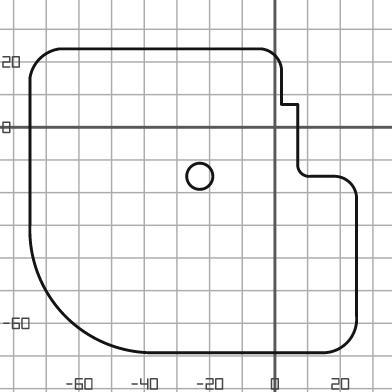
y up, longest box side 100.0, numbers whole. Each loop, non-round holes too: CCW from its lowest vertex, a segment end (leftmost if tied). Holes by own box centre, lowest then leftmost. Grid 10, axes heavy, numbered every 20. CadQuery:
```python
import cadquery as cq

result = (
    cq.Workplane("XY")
    .moveTo(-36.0, -69.0)
    .lineTo(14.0, -69.0)
    .threePointArc((22.0, -66.0), (25.0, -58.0))
    .lineTo(25.0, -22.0)
    .threePointArc((23.0, -17.0), (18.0, -15.0))
    .lineTo(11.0, -15.0)
    .threePointArc((8.0, -14.0), (7.0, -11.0))
    .lineTo(7.0, 7.0)
    .lineTo(2.0, 7.0)
    .lineTo(2.0, 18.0)
    .threePointArc((0.0, 22.0), (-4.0, 24.0))
    .lineTo(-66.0, 24.0)
    .threePointArc((-72.0, 21.0), (-75.0, 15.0))
    .lineTo(-75.0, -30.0)
    .threePointArc((-64.0, -58.0), (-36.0, -69.0))
    .close()
    .moveTo(-23.0, -15.0)
    .circle(4.0)
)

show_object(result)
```